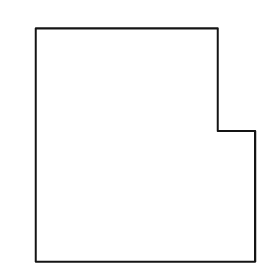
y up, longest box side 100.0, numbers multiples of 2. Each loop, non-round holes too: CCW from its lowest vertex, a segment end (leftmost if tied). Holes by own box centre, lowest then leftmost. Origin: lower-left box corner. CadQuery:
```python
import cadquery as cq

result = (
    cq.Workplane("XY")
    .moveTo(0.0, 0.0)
    .lineTo(94.0, 0.0)
    .lineTo(94.0, 56.0)
    .lineTo(78.0, 56.0)
    .lineTo(78.0, 100.0)
    .lineTo(0.0, 100.0)
    .close()
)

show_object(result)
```